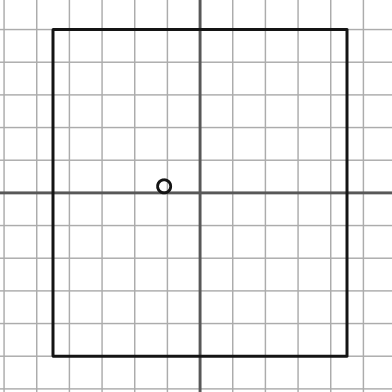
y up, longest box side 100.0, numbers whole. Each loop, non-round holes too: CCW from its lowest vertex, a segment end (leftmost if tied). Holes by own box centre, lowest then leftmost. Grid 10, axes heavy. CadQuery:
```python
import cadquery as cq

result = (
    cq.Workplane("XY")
    .moveTo(-45.0, -50.0)
    .lineTo(45.0, -50.0)
    .lineTo(45.0, 50.0)
    .lineTo(-45.0, 50.0)
    .close()
    .moveTo(-11.0, 2.0)
    .circle(2.0)
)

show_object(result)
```